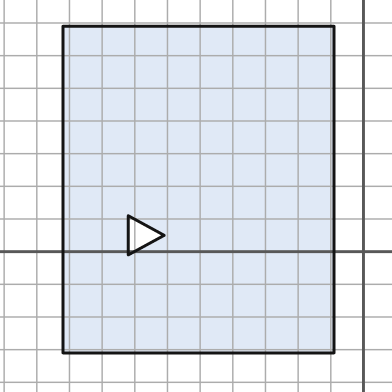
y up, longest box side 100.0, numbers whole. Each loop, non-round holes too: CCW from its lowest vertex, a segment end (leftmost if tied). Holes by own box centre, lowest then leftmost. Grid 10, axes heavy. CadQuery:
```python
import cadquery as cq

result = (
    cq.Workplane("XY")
    .moveTo(-92.0, -31.0)
    .lineTo(-9.0, -31.0)
    .lineTo(-9.0, 69.0)
    .lineTo(-92.0, 69.0)
    .close()
    .moveTo(-72.0, -1.0)
    .lineTo(-61.0, 5.0)
    .lineTo(-72.0, 11.0)
    .close()
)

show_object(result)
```